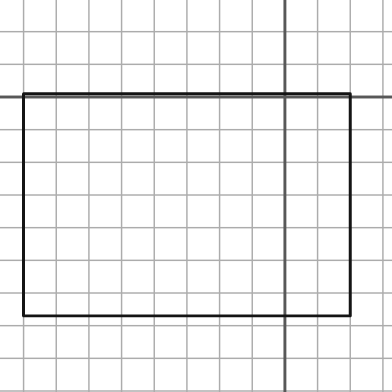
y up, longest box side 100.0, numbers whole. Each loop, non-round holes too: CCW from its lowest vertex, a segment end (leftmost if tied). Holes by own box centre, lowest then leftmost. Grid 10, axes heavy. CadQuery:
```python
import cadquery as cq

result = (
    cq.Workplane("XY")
    .moveTo(-80.0, -67.0)
    .lineTo(20.0, -67.0)
    .lineTo(20.0, 1.0)
    .lineTo(-80.0, 1.0)
    .close()
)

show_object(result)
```